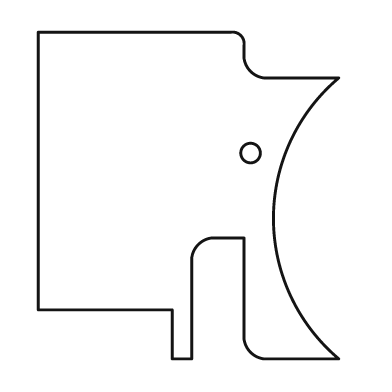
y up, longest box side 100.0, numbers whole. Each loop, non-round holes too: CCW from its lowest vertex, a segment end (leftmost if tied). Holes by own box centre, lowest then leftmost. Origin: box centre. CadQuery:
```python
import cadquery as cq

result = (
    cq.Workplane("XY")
    .moveTo(-5.0, -50.0)
    .lineTo(1.0, -50.0)
    .lineTo(1.0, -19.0)
    .threePointArc((3.0, -15.0), (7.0, -13.0))
    .lineTo(17.0, -13.0)
    .lineTo(17.0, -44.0)
    .threePointArc((19.0, -48.0), (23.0, -50.0))
    .lineTo(46.0, -50.0)
    .threePointArc((26.0, -7.0), (46.0, 36.0))
    .lineTo(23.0, 36.0)
    .threePointArc((19.0, 38.0), (17.0, 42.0))
    .lineTo(17.0, 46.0)
    .threePointArc((16.0, 49.0), (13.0, 50.0))
    .lineTo(-46.0, 50.0)
    .lineTo(-46.0, -35.0)
    .lineTo(-5.0, -35.0)
    .close()
    .moveTo(19.0, 13.0)
    .circle(3.0)
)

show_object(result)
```